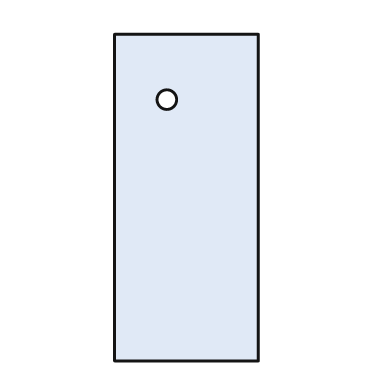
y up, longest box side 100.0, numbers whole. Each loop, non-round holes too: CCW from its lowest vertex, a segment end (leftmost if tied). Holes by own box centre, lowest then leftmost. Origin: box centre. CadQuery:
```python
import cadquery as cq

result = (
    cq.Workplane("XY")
    .moveTo(-22.0, -50.0)
    .lineTo(22.0, -50.0)
    .lineTo(22.0, 50.0)
    .lineTo(-22.0, 50.0)
    .close()
    .moveTo(-6.0, 30.0)
    .circle(3.0)
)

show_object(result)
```